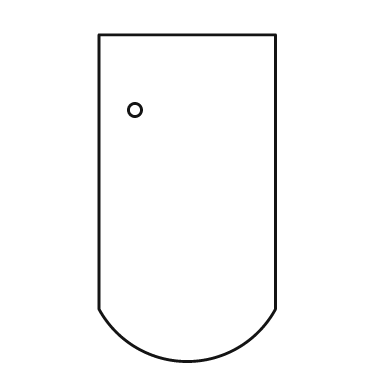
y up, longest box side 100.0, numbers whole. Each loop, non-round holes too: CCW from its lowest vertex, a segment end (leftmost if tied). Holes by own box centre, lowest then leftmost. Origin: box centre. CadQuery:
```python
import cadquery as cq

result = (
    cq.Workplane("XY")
    .moveTo(-27.0, -34.0)
    .threePointArc((0.0, -50.0), (27.0, -34.0))
    .lineTo(27.0, 50.0)
    .lineTo(-27.0, 50.0)
    .close()
    .moveTo(-16.0, 27.0)
    .circle(2.0)
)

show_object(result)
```